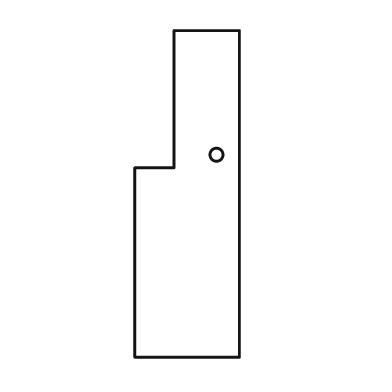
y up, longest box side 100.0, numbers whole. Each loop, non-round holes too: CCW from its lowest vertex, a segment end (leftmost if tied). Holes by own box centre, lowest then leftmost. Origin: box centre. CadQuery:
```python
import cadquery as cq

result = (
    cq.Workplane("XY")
    .moveTo(-16.0, -50.0)
    .lineTo(16.0, -50.0)
    .lineTo(16.0, 50.0)
    .lineTo(-4.0, 50.0)
    .lineTo(-4.0, 8.0)
    .lineTo(-16.0, 8.0)
    .close()
    .moveTo(9.0, 12.0)
    .circle(2.0)
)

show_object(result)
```